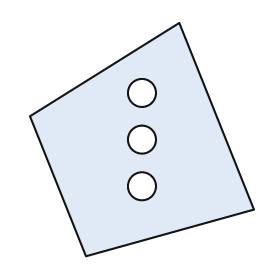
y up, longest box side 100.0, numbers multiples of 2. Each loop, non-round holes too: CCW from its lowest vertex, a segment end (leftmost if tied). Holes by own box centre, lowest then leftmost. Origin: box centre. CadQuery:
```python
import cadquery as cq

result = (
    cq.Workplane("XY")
    .moveTo(-24.0, -50.0)
    .lineTo(48.0, -30.0)
    .lineTo(16.0, 50.0)
    .lineTo(-48.0, 10.0)
    .close()
    .moveTo(0.0, -20.0)
    .circle(6.0)
    .moveTo(0.0, 0.0)
    .circle(6.0)
    .moveTo(0.0, 20.0)
    .circle(6.0)
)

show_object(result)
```